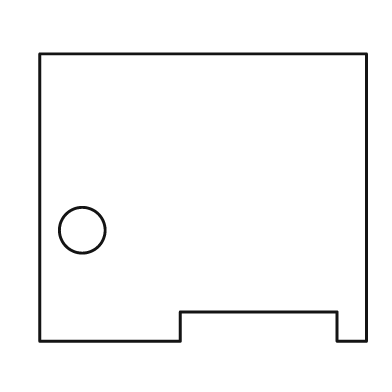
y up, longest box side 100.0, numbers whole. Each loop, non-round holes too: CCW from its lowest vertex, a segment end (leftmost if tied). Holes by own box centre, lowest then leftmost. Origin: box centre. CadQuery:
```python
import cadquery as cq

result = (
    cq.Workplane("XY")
    .moveTo(-50.0, -44.0)
    .lineTo(-7.0, -44.0)
    .lineTo(-7.0, -35.0)
    .lineTo(41.0, -35.0)
    .lineTo(41.0, -44.0)
    .lineTo(50.0, -44.0)
    .lineTo(50.0, 44.0)
    .lineTo(-50.0, 44.0)
    .close()
    .moveTo(-37.0, -10.0)
    .circle(7.0)
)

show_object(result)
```